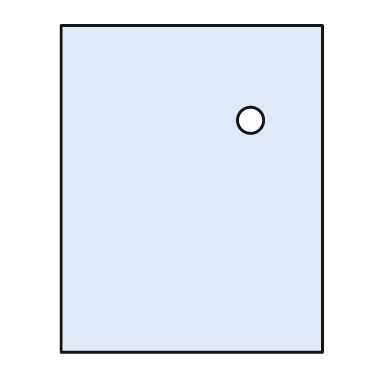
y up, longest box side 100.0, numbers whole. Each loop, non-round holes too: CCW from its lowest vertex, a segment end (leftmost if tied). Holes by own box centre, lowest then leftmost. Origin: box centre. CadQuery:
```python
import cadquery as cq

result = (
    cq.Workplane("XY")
    .moveTo(-40.0, -50.0)
    .lineTo(40.0, -50.0)
    .lineTo(40.0, 50.0)
    .lineTo(-40.0, 50.0)
    .close()
    .moveTo(18.0, 21.0)
    .circle(4.0)
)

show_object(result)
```